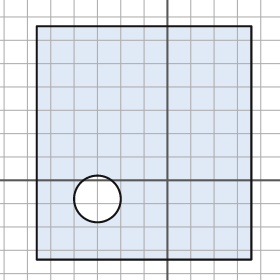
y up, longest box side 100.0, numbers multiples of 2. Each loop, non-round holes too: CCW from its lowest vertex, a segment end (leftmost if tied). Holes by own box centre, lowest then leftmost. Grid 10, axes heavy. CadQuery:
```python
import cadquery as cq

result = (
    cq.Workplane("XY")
    .moveTo(-56.0, -34.0)
    .lineTo(36.0, -34.0)
    .lineTo(36.0, 66.0)
    .lineTo(-56.0, 66.0)
    .close()
    .moveTo(-30.0, -8.0)
    .circle(10.0)
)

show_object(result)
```